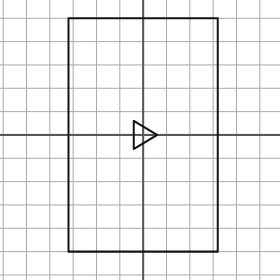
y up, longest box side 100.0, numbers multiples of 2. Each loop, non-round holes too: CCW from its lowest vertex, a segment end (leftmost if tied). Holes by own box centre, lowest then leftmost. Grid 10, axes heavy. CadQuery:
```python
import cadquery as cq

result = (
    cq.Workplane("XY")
    .moveTo(-32.0, -50.0)
    .lineTo(32.0, -50.0)
    .lineTo(32.0, 50.0)
    .lineTo(-32.0, 50.0)
    .close()
    .moveTo(-4.0, -6.0)
    .lineTo(6.0, 0.0)
    .lineTo(-4.0, 6.0)
    .close()
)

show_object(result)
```